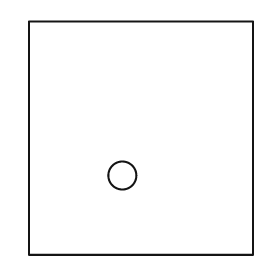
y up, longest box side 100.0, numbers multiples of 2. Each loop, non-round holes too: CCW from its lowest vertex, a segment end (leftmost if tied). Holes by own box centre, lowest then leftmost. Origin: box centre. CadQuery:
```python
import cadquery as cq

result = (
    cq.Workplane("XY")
    .moveTo(-48.0, -50.0)
    .lineTo(48.0, -50.0)
    .lineTo(48.0, 50.0)
    .lineTo(-48.0, 50.0)
    .close()
    .moveTo(-8.0, -16.0)
    .circle(6.0)
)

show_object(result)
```